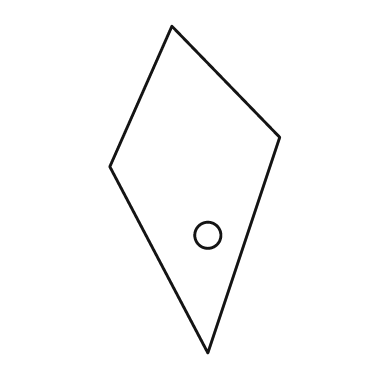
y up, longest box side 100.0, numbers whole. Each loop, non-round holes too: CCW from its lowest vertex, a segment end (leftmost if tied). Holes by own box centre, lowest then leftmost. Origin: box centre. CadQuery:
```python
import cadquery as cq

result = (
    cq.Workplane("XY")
    .moveTo(4.0, -50.0)
    .lineTo(26.0, 16.0)
    .lineTo(-7.0, 50.0)
    .lineTo(-26.0, 7.0)
    .close()
    .moveTo(4.0, -14.0)
    .circle(4.0)
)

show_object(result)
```